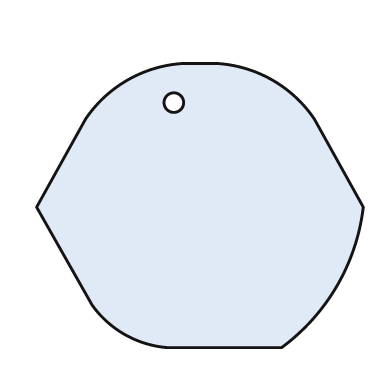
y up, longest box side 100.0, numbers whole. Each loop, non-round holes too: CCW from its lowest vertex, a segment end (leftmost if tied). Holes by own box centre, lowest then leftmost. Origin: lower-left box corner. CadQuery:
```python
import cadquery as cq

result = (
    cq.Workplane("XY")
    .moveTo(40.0, 0.0)
    .lineTo(75.0, 0.0)
    .threePointArc((92.0, 19.0), (100.0, 43.0))
    .lineTo(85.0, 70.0)
    .threePointArc((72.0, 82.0), (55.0, 87.0))
    .lineTo(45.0, 87.0)
    .threePointArc((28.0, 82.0), (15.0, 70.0))
    .lineTo(0.0, 43.0)
    .lineTo(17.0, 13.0)
    .threePointArc((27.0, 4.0), (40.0, 0.0))
    .close()
    .moveTo(42.0, 75.0)
    .circle(3.0)
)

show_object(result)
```